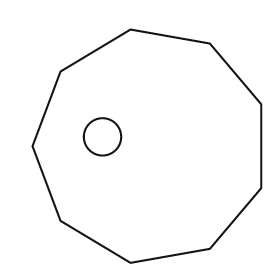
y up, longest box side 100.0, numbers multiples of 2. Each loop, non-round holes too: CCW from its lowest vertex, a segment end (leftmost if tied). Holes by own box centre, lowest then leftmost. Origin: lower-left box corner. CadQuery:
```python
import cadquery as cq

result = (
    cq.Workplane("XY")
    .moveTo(42.0, 0.0)
    .lineTo(76.0, 6.0)
    .lineTo(98.0, 32.0)
    .lineTo(98.0, 68.0)
    .lineTo(76.0, 94.0)
    .lineTo(42.0, 100.0)
    .lineTo(12.0, 82.0)
    .lineTo(0.0, 50.0)
    .lineTo(12.0, 18.0)
    .close()
    .moveTo(30.0, 54.0)
    .circle(8.0)
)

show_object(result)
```